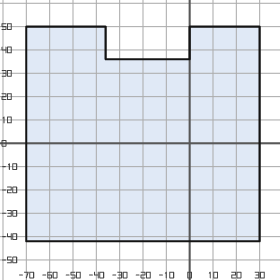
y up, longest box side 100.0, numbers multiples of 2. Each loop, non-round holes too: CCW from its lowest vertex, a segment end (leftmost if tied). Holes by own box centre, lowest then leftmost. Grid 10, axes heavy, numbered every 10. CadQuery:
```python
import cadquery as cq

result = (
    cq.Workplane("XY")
    .moveTo(-70.0, -42.0)
    .lineTo(30.0, -42.0)
    .lineTo(30.0, 50.0)
    .lineTo(0.0, 50.0)
    .lineTo(0.0, 36.0)
    .lineTo(-36.0, 36.0)
    .lineTo(-36.0, 50.0)
    .lineTo(-70.0, 50.0)
    .close()
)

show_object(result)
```